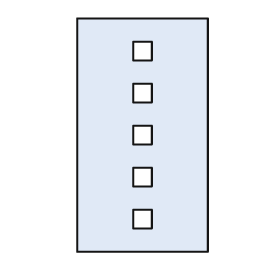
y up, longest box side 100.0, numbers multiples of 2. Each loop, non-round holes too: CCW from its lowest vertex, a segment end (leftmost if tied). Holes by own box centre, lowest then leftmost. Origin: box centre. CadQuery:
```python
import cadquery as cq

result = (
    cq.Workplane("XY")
    .moveTo(-28.0, -50.0)
    .lineTo(28.0, -50.0)
    .lineTo(28.0, 50.0)
    .lineTo(-28.0, 50.0)
    .close()
    .moveTo(-4.0, -40.0)
    .lineTo(4.0, -40.0)
    .lineTo(4.0, -32.0)
    .lineTo(-4.0, -32.0)
    .close()
    .moveTo(-4.0, -22.0)
    .lineTo(4.0, -22.0)
    .lineTo(4.0, -14.0)
    .lineTo(-4.0, -14.0)
    .close()
    .moveTo(-4.0, -4.0)
    .lineTo(4.0, -4.0)
    .lineTo(4.0, 4.0)
    .lineTo(-4.0, 4.0)
    .close()
    .moveTo(-4.0, 14.0)
    .lineTo(4.0, 14.0)
    .lineTo(4.0, 22.0)
    .lineTo(-4.0, 22.0)
    .close()
    .moveTo(-4.0, 32.0)
    .lineTo(4.0, 32.0)
    .lineTo(4.0, 40.0)
    .lineTo(-4.0, 40.0)
    .close()
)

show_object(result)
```